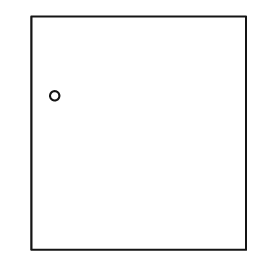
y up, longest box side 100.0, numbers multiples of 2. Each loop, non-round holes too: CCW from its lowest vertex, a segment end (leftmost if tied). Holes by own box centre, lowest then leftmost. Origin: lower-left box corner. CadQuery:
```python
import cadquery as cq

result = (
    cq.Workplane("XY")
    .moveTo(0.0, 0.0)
    .lineTo(92.0, 0.0)
    .lineTo(92.0, 100.0)
    .lineTo(0.0, 100.0)
    .close()
    .moveTo(10.0, 66.0)
    .circle(2.0)
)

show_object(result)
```